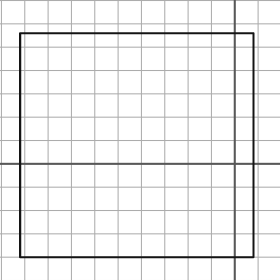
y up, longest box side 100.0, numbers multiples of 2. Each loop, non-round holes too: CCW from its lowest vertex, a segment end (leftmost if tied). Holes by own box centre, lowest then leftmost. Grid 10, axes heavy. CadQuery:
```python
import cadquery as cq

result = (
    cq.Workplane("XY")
    .moveTo(-92.0, -40.0)
    .lineTo(8.0, -40.0)
    .lineTo(8.0, 56.0)
    .lineTo(-92.0, 56.0)
    .close()
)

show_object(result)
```